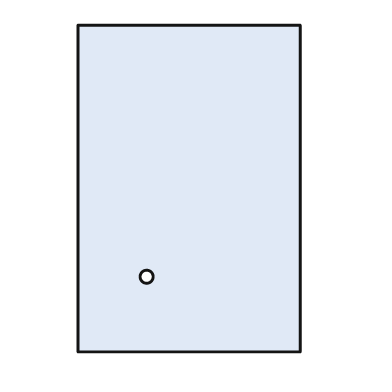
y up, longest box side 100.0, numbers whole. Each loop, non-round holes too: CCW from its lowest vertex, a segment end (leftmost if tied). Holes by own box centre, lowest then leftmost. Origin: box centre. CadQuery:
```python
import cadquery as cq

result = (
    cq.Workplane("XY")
    .moveTo(-34.0, -50.0)
    .lineTo(34.0, -50.0)
    .lineTo(34.0, 50.0)
    .lineTo(-34.0, 50.0)
    .close()
    .moveTo(-13.0, -27.0)
    .circle(2.0)
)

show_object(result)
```